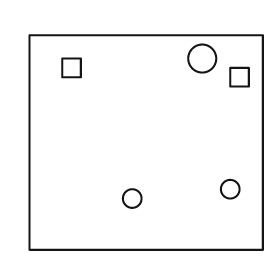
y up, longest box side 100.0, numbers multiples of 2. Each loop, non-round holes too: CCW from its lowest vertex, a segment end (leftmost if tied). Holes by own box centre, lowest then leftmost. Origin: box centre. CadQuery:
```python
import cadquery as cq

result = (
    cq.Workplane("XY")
    .moveTo(-50.0, -46.0)
    .lineTo(50.0, -46.0)
    .lineTo(50.0, 46.0)
    .lineTo(-50.0, 46.0)
    .close()
    .moveTo(-6.0, -24.0)
    .circle(4.0)
    .moveTo(36.0, -20.0)
    .circle(4.0)
    .moveTo(36.0, 24.0)
    .lineTo(44.0, 24.0)
    .lineTo(44.0, 32.0)
    .lineTo(36.0, 32.0)
    .close()
    .moveTo(-36.0, 28.0)
    .lineTo(-28.0, 28.0)
    .lineTo(-28.0, 36.0)
    .lineTo(-36.0, 36.0)
    .close()
    .moveTo(24.0, 36.0)
    .circle(6.0)
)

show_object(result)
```